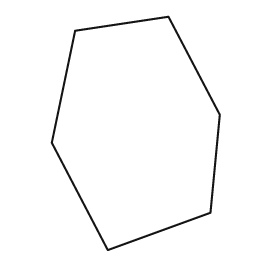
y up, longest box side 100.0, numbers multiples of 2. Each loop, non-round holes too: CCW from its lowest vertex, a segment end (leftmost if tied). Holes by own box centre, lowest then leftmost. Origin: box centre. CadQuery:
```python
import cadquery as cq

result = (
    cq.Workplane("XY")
    .moveTo(-12.0, -50.0)
    .lineTo(32.0, -34.0)
    .lineTo(36.0, 8.0)
    .lineTo(14.0, 50.0)
    .lineTo(-26.0, 44.0)
    .lineTo(-36.0, -4.0)
    .close()
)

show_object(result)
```